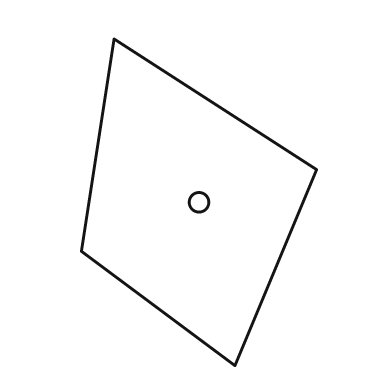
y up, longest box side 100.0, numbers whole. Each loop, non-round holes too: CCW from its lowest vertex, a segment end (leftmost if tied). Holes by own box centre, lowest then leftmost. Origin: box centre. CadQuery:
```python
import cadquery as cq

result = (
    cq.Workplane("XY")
    .moveTo(11.0, -50.0)
    .lineTo(36.0, 10.0)
    .lineTo(-26.0, 50.0)
    .lineTo(-36.0, -15.0)
    .close()
    .moveTo(0.0, 0.0)
    .circle(3.0)
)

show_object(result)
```